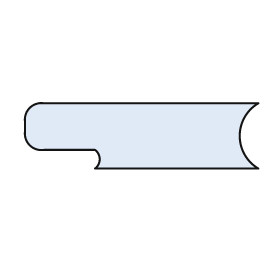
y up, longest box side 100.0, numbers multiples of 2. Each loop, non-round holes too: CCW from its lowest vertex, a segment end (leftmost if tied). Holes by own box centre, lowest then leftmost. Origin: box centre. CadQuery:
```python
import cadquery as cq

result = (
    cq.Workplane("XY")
    .moveTo(-20.0, -14.0)
    .lineTo(50.0, -14.0)
    .threePointArc((42.0, 0.0), (50.0, 14.0))
    .lineTo(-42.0, 14.0)
    .threePointArc((-48.0, 12.0), (-50.0, 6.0))
    .lineTo(-50.0, 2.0)
    .threePointArc((-48.0, -4.0), (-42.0, -6.0))
    .lineTo(-20.0, -6.0)
    .threePointArc((-18.0, -10.0), (-20.0, -14.0))
    .close()
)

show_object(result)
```